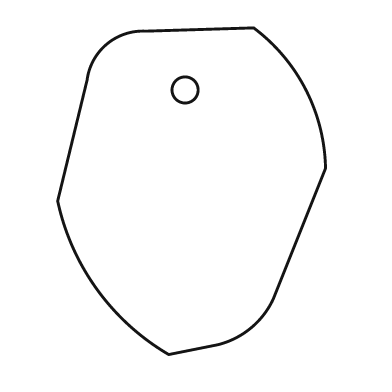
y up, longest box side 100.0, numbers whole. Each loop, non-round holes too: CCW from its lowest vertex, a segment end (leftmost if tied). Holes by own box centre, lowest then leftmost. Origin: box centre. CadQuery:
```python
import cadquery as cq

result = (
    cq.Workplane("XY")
    .moveTo(-7.0, -50.0)
    .lineTo(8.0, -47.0)
    .threePointArc((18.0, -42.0), (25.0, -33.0))
    .lineTo(41.0, 7.0)
    .threePointArc((35.0, 31.0), (19.0, 50.0))
    .lineTo(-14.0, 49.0)
    .threePointArc((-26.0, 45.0), (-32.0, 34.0))
    .lineTo(-41.0, -3.0)
    .threePointArc((-29.0, -30.0), (-7.0, -50.0))
    .close()
    .moveTo(-2.0, 31.0)
    .circle(4.0)
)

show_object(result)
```